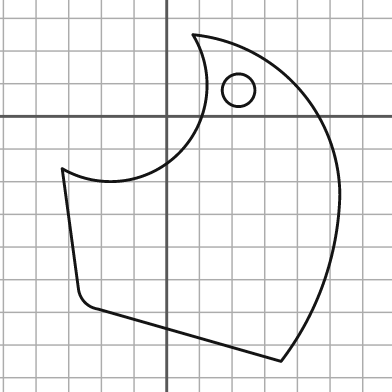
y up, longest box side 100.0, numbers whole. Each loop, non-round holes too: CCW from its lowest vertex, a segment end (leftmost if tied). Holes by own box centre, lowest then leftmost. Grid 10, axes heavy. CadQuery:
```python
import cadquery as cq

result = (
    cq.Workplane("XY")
    .moveTo(35.0, -75.0)
    .threePointArc((48.0, -51.0), (53.0, -24.0))
    .threePointArc((40.0, 9.0), (8.0, 25.0))
    .threePointArc((4.0, -11.0), (-32.0, -16.0))
    .lineTo(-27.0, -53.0)
    .threePointArc((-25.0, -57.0), (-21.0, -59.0))
    .close()
    .moveTo(22.0, 8.0)
    .circle(5.0)
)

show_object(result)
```